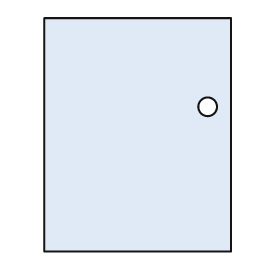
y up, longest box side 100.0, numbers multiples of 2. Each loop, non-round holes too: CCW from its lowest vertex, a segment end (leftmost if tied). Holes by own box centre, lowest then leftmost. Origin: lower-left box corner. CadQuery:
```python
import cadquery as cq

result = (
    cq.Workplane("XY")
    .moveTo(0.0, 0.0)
    .lineTo(80.0, 0.0)
    .lineTo(80.0, 100.0)
    .lineTo(0.0, 100.0)
    .close()
    .moveTo(70.0, 62.0)
    .circle(4.0)
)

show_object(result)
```